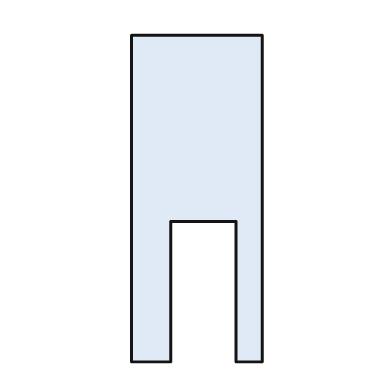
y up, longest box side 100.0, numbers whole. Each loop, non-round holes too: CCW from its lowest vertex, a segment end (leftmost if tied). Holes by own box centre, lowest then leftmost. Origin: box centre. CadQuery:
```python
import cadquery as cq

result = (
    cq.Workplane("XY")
    .moveTo(-20.0, -50.0)
    .lineTo(-8.0, -50.0)
    .lineTo(-8.0, -7.0)
    .lineTo(12.0, -7.0)
    .lineTo(12.0, -50.0)
    .lineTo(20.0, -50.0)
    .lineTo(20.0, 50.0)
    .lineTo(-20.0, 50.0)
    .close()
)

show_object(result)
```